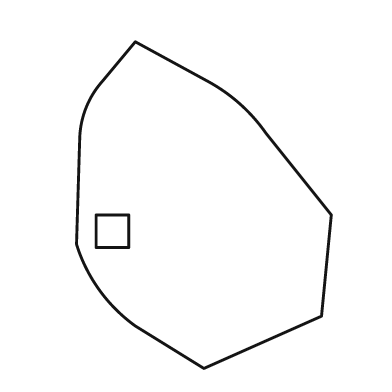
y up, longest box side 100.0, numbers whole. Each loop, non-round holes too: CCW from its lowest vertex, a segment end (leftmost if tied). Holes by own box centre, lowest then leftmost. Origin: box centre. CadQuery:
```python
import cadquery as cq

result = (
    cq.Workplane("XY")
    .moveTo(0.0, -50.0)
    .lineTo(36.0, -34.0)
    .lineTo(39.0, -3.0)
    .lineTo(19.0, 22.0)
    .threePointArc((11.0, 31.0), (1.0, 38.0))
    .lineTo(-21.0, 50.0)
    .lineTo(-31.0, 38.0)
    .threePointArc((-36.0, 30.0), (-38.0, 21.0))
    .lineTo(-39.0, -12.0)
    .threePointArc((-32.0, -26.0), (-21.0, -37.0))
    .close()
    .moveTo(-33.0, -13.0)
    .lineTo(-23.0, -13.0)
    .lineTo(-23.0, -3.0)
    .lineTo(-33.0, -3.0)
    .close()
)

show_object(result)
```